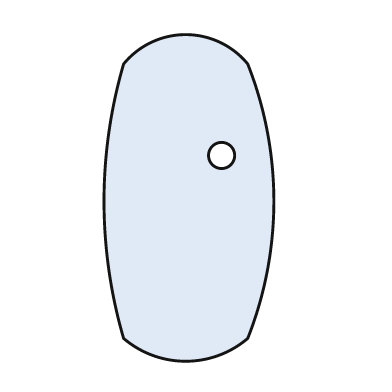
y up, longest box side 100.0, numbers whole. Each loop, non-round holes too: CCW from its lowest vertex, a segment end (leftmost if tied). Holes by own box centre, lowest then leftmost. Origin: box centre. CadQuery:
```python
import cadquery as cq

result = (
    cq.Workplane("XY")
    .moveTo(-20.0, -43.0)
    .threePointArc((-1.0, -50.0), (18.0, -43.0))
    .threePointArc((26.0, -1.0), (18.0, 41.0))
    .threePointArc((-1.0, 50.0), (-20.0, 41.0))
    .threePointArc((-26.0, -1.0), (-20.0, -43.0))
    .close()
    .moveTo(10.0, 13.0)
    .circle(4.0)
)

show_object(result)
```